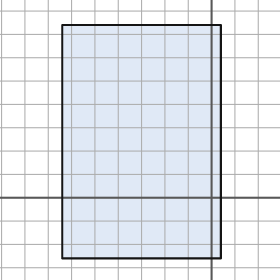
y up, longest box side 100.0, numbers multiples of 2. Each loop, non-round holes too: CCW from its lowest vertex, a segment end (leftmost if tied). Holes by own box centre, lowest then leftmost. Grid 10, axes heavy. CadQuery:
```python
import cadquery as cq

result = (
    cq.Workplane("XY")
    .moveTo(-64.0, -26.0)
    .lineTo(4.0, -26.0)
    .lineTo(4.0, 74.0)
    .lineTo(-64.0, 74.0)
    .close()
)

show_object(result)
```